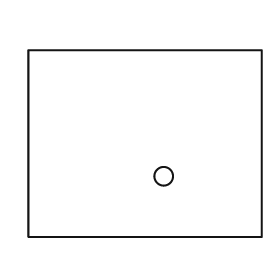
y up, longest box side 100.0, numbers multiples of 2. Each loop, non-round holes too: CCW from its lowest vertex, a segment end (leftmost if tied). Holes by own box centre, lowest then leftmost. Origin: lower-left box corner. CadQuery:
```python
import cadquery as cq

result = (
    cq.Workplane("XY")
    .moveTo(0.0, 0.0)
    .lineTo(100.0, 0.0)
    .lineTo(100.0, 80.0)
    .lineTo(0.0, 80.0)
    .close()
    .moveTo(58.0, 26.0)
    .circle(4.0)
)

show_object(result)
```